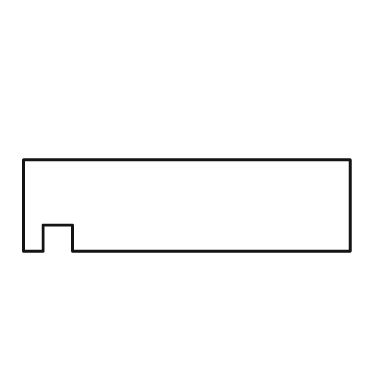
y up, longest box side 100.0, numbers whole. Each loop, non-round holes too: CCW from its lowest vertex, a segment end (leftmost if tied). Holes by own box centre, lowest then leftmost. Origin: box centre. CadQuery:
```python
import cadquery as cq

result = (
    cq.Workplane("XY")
    .moveTo(-50.0, -14.0)
    .lineTo(-44.0, -14.0)
    .lineTo(-44.0, -6.0)
    .lineTo(-35.0, -6.0)
    .lineTo(-35.0, -14.0)
    .lineTo(50.0, -14.0)
    .lineTo(50.0, 14.0)
    .lineTo(-50.0, 14.0)
    .close()
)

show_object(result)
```